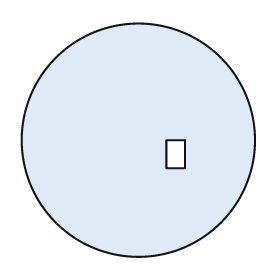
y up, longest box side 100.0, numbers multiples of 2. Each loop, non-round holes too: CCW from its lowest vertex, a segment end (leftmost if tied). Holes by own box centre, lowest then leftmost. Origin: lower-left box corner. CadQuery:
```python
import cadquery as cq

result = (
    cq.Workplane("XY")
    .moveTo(50.0, 50.0)
    .circle(50.0)
    .moveTo(62.0, 38.0)
    .lineTo(70.0, 38.0)
    .lineTo(70.0, 50.0)
    .lineTo(62.0, 50.0)
    .close()
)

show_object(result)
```